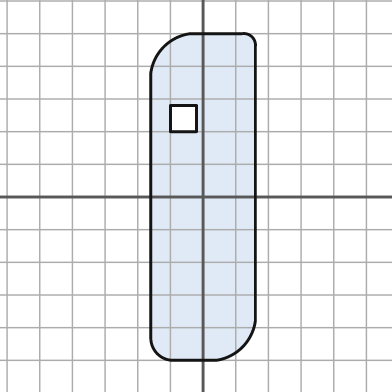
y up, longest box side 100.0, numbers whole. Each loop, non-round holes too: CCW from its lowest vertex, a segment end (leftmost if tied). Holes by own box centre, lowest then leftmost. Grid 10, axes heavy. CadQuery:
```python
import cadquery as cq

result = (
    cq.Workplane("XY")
    .moveTo(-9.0, -50.0)
    .lineTo(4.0, -50.0)
    .threePointArc((12.0, -46.0), (16.0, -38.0))
    .lineTo(16.0, 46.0)
    .threePointArc((15.0, 49.0), (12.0, 50.0))
    .lineTo(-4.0, 50.0)
    .threePointArc((-12.0, 46.0), (-16.0, 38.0))
    .lineTo(-16.0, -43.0)
    .threePointArc((-14.0, -48.0), (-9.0, -50.0))
    .close()
    .moveTo(-10.0, 20.0)
    .lineTo(-2.0, 20.0)
    .lineTo(-2.0, 28.0)
    .lineTo(-10.0, 28.0)
    .close()
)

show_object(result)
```